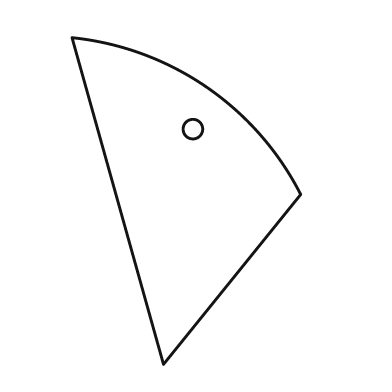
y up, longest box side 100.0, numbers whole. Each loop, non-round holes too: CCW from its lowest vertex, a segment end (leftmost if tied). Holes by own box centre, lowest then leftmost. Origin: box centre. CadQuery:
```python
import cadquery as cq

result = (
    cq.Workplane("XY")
    .moveTo(-7.0, -50.0)
    .lineTo(35.0, 2.0)
    .threePointArc((6.0, 35.0), (-35.0, 50.0))
    .close()
    .moveTo(2.0, 22.0)
    .circle(3.0)
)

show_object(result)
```